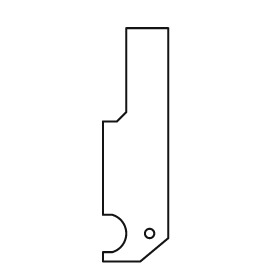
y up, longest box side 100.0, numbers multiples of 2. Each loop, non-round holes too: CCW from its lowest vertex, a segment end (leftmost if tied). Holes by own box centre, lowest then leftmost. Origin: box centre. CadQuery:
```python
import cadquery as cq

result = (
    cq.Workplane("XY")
    .moveTo(-14.0, -50.0)
    .lineTo(2.0, -50.0)
    .lineTo(14.0, -40.0)
    .lineTo(14.0, 50.0)
    .lineTo(-4.0, 50.0)
    .lineTo(-4.0, 14.0)
    .lineTo(-8.0, 10.0)
    .lineTo(-14.0, 10.0)
    .lineTo(-14.0, -30.0)
    .lineTo(-10.0, -30.0)
    .threePointArc((-4.0, -38.0), (-10.0, -46.0))
    .lineTo(-14.0, -46.0)
    .close()
    .moveTo(6.0, -38.0)
    .circle(2.0)
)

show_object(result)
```